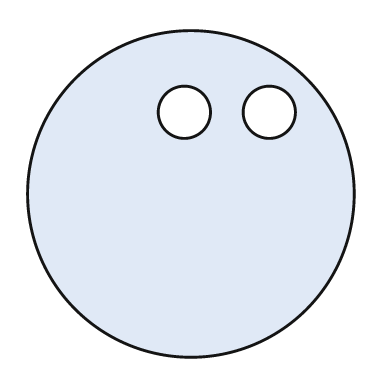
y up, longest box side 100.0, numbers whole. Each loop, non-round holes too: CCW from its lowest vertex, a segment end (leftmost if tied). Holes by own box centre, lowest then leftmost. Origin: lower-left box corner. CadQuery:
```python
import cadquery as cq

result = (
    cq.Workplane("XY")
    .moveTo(50.0, 50.0)
    .circle(50.0)
    .moveTo(48.0, 75.0)
    .circle(8.0)
    .moveTo(74.0, 75.0)
    .circle(8.0)
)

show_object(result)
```